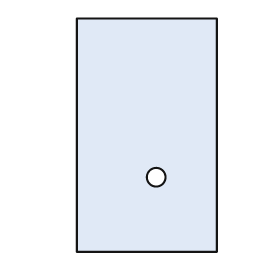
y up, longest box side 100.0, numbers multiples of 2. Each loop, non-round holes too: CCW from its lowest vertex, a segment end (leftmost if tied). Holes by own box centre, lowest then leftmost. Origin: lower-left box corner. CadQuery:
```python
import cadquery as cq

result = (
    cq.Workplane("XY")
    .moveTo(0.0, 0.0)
    .lineTo(60.0, 0.0)
    .lineTo(60.0, 100.0)
    .lineTo(0.0, 100.0)
    .close()
    .moveTo(34.0, 32.0)
    .circle(4.0)
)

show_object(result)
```